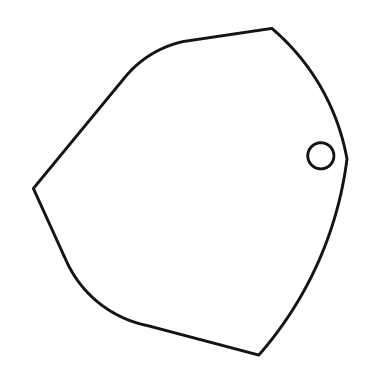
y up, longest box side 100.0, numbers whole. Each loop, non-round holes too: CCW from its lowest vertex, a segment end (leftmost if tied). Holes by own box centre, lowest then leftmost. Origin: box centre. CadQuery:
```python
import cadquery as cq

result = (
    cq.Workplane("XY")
    .moveTo(21.0, -50.0)
    .threePointArc((39.0, -22.0), (48.0, 10.0))
    .threePointArc((40.0, 32.0), (25.0, 50.0))
    .lineTo(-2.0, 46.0)
    .threePointArc((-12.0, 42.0), (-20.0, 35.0))
    .lineTo(-48.0, 1.0)
    .lineTo(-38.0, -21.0)
    .threePointArc((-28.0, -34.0), (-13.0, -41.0))
    .close()
    .moveTo(40.0, 11.0)
    .circle(4.0)
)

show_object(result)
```